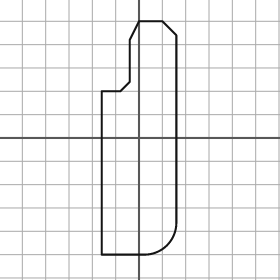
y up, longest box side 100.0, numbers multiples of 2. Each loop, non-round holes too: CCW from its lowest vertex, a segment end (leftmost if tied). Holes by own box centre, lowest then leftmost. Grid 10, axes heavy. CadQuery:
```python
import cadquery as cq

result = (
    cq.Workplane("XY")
    .moveTo(-16.0, -50.0)
    .lineTo(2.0, -50.0)
    .threePointArc((12.0, -46.0), (16.0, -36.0))
    .lineTo(16.0, 44.0)
    .lineTo(10.0, 50.0)
    .lineTo(0.0, 50.0)
    .lineTo(-4.0, 42.0)
    .lineTo(-4.0, 24.0)
    .lineTo(-8.0, 20.0)
    .lineTo(-16.0, 20.0)
    .close()
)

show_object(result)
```